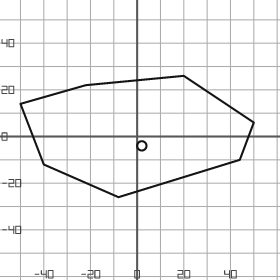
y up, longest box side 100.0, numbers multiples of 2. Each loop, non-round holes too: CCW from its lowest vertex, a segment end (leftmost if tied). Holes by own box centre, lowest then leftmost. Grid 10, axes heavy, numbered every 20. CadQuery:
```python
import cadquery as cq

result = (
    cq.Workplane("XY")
    .moveTo(-8.0, -26.0)
    .lineTo(44.0, -10.0)
    .lineTo(50.0, 6.0)
    .lineTo(20.0, 26.0)
    .lineTo(-22.0, 22.0)
    .lineTo(-50.0, 14.0)
    .lineTo(-40.0, -12.0)
    .close()
    .moveTo(2.0, -4.0)
    .circle(2.0)
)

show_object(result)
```